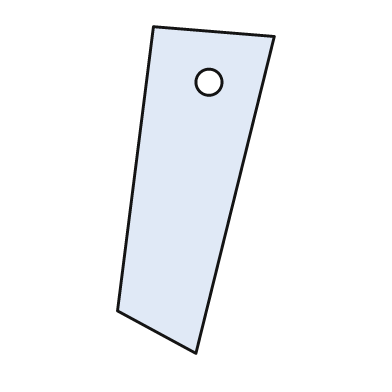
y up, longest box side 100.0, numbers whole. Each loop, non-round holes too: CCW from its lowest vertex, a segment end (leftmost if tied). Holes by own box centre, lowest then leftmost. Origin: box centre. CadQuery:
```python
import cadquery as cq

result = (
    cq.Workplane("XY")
    .moveTo(0.0, -50.0)
    .lineTo(24.0, 47.0)
    .lineTo(-13.0, 50.0)
    .lineTo(-24.0, -37.0)
    .close()
    .moveTo(4.0, 33.0)
    .circle(4.0)
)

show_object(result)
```